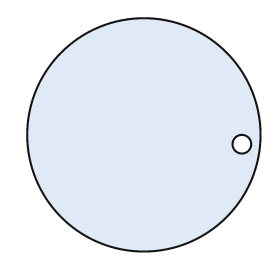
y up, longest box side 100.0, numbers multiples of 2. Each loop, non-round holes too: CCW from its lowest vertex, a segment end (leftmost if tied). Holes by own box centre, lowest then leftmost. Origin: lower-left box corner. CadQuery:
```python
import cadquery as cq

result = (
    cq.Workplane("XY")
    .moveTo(50.0, 50.0)
    .circle(50.0)
    .moveTo(92.0, 46.0)
    .circle(4.0)
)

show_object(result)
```